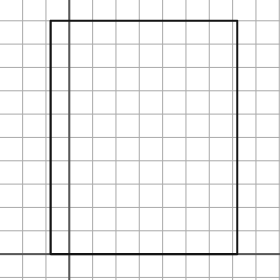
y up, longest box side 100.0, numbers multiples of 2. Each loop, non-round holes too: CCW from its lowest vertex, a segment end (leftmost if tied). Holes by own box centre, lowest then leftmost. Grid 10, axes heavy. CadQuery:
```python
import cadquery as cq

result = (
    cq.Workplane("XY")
    .moveTo(-8.0, 0.0)
    .lineTo(72.0, 0.0)
    .lineTo(72.0, 100.0)
    .lineTo(-8.0, 100.0)
    .close()
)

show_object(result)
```